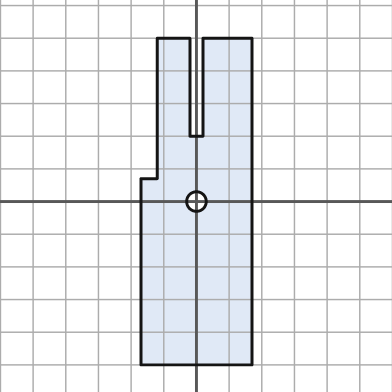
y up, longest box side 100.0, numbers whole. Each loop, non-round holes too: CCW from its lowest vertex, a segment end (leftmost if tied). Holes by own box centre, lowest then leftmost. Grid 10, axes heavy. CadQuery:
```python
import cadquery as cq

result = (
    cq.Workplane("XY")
    .moveTo(-17.0, -50.0)
    .lineTo(17.0, -50.0)
    .lineTo(17.0, 50.0)
    .lineTo(2.0, 50.0)
    .lineTo(2.0, 20.0)
    .lineTo(-2.0, 20.0)
    .lineTo(-2.0, 50.0)
    .lineTo(-12.0, 50.0)
    .lineTo(-12.0, 7.0)
    .lineTo(-17.0, 7.0)
    .close()
    .moveTo(0.0, 0.0)
    .circle(3.0)
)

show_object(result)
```